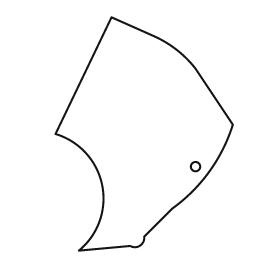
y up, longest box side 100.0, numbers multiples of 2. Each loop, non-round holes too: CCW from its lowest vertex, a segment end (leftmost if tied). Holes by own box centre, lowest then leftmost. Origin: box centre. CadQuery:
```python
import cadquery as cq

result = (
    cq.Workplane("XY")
    .moveTo(-28.0, -50.0)
    .lineTo(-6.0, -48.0)
    .threePointArc((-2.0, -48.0), (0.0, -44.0))
    .lineTo(12.0, -32.0)
    .threePointArc((28.0, -16.0), (38.0, 4.0))
    .lineTo(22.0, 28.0)
    .threePointArc((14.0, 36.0), (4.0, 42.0))
    .lineTo(-14.0, 50.0)
    .lineTo(-38.0, 0.0)
    .threePointArc((-18.0, -22.0), (-28.0, -50.0))
    .close()
    .moveTo(22.0, -14.0)
    .circle(2.0)
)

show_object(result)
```